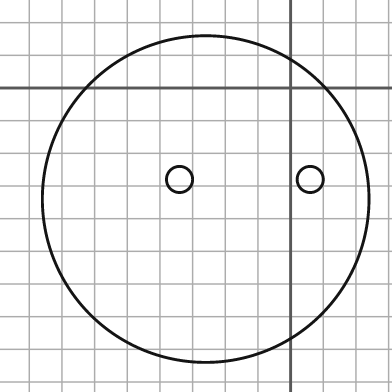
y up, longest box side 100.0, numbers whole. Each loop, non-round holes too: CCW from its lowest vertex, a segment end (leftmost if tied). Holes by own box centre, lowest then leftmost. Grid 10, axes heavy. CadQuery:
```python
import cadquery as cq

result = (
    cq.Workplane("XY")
    .moveTo(-26.0, -34.0)
    .circle(50.0)
    .moveTo(-34.0, -28.0)
    .circle(4.0)
    .moveTo(6.0, -28.0)
    .circle(4.0)
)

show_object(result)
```